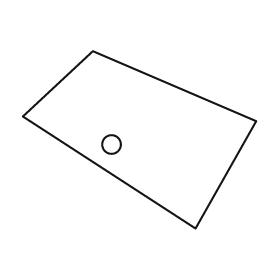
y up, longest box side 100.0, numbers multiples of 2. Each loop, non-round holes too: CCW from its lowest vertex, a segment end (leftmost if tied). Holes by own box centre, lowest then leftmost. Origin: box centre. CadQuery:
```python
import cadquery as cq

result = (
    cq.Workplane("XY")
    .moveTo(24.0, -38.0)
    .lineTo(50.0, 8.0)
    .lineTo(-20.0, 38.0)
    .lineTo(-50.0, 10.0)
    .close()
    .moveTo(-12.0, -2.0)
    .circle(4.0)
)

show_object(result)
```